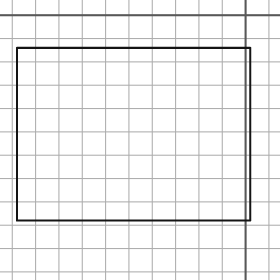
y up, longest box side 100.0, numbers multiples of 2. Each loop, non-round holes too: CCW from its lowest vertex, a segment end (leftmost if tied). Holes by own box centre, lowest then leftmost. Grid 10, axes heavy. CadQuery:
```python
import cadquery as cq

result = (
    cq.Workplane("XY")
    .moveTo(-98.0, -88.0)
    .lineTo(2.0, -88.0)
    .lineTo(2.0, -14.0)
    .lineTo(-98.0, -14.0)
    .close()
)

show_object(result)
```